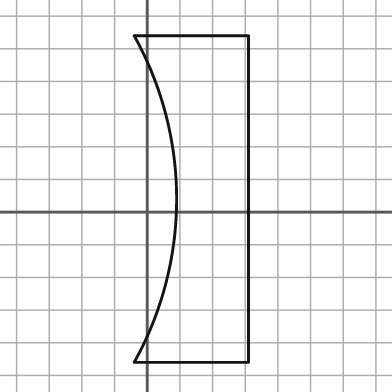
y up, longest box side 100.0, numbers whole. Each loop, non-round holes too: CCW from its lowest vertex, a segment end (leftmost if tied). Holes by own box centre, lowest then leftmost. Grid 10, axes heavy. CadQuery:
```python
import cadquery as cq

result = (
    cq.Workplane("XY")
    .moveTo(-4.0, -46.0)
    .lineTo(31.0, -46.0)
    .lineTo(31.0, 54.0)
    .lineTo(-4.0, 54.0)
    .threePointArc((9.0, 4.0), (-4.0, -46.0))
    .close()
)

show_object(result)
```